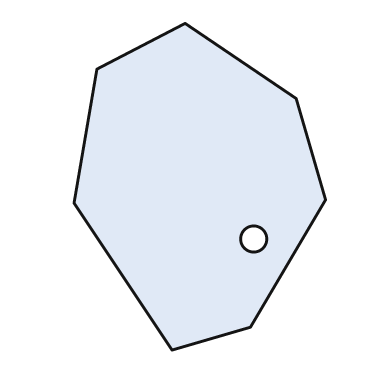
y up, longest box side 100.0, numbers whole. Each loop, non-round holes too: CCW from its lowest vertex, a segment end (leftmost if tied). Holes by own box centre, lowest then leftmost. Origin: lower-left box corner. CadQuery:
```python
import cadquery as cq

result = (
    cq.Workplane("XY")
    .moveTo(30.0, 0.0)
    .lineTo(54.0, 7.0)
    .lineTo(77.0, 46.0)
    .lineTo(68.0, 77.0)
    .lineTo(34.0, 100.0)
    .lineTo(7.0, 86.0)
    .lineTo(0.0, 45.0)
    .close()
    .moveTo(55.0, 34.0)
    .circle(4.0)
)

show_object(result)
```